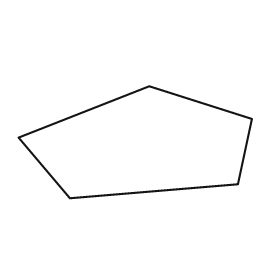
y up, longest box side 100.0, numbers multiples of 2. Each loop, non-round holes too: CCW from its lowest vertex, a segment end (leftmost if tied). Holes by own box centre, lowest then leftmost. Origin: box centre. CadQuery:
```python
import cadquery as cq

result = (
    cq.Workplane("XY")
    .moveTo(-28.0, -24.0)
    .lineTo(44.0, -18.0)
    .lineTo(50.0, 10.0)
    .lineTo(6.0, 24.0)
    .lineTo(-50.0, 2.0)
    .close()
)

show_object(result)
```